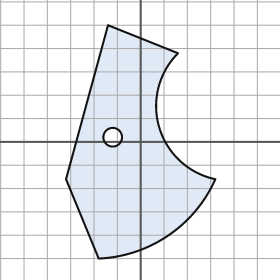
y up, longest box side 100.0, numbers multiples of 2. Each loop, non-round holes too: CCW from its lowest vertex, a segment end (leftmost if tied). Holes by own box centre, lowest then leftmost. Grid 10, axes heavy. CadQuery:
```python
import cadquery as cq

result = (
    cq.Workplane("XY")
    .moveTo(-18.0, -50.0)
    .threePointArc((12.0, -40.0), (32.0, -16.0))
    .threePointArc((8.0, 6.0), (16.0, 38.0))
    .lineTo(-14.0, 50.0)
    .lineTo(-32.0, -16.0)
    .close()
    .moveTo(-12.0, 2.0)
    .circle(4.0)
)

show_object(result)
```